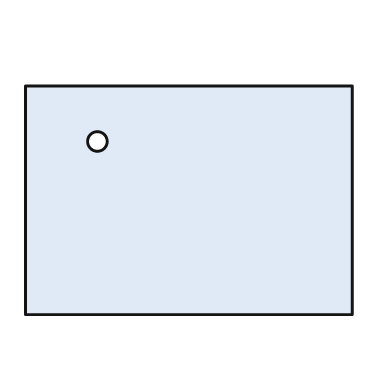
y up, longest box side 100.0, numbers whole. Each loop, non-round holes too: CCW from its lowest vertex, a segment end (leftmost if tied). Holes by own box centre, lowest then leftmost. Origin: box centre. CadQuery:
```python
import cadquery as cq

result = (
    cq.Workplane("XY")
    .moveTo(-50.0, -35.0)
    .lineTo(50.0, -35.0)
    .lineTo(50.0, 35.0)
    .lineTo(-50.0, 35.0)
    .close()
    .moveTo(-28.0, 18.0)
    .circle(3.0)
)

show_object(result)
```